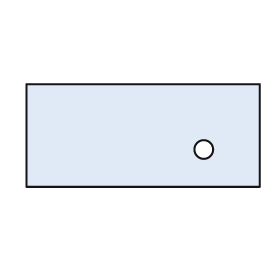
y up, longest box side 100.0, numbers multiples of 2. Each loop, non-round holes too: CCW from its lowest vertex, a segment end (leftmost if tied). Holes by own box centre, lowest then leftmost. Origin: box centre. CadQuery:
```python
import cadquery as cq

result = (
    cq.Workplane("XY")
    .moveTo(-50.0, -22.0)
    .lineTo(50.0, -22.0)
    .lineTo(50.0, 22.0)
    .lineTo(-50.0, 22.0)
    .close()
    .moveTo(26.0, -6.0)
    .circle(4.0)
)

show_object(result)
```